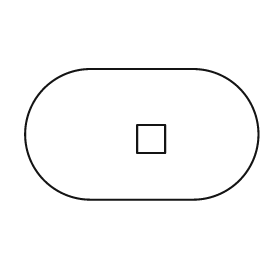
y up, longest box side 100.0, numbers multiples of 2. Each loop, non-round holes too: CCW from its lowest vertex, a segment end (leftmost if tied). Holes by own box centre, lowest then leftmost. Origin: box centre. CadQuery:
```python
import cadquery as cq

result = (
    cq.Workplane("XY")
    .moveTo(-22.0, -28.0)
    .lineTo(22.0, -28.0)
    .threePointArc((50.0, 0.0), (22.0, 28.0))
    .lineTo(-22.0, 28.0)
    .threePointArc((-50.0, 0.0), (-22.0, -28.0))
    .close()
    .moveTo(-2.0, -8.0)
    .lineTo(10.0, -8.0)
    .lineTo(10.0, 4.0)
    .lineTo(-2.0, 4.0)
    .close()
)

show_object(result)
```